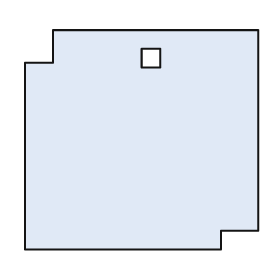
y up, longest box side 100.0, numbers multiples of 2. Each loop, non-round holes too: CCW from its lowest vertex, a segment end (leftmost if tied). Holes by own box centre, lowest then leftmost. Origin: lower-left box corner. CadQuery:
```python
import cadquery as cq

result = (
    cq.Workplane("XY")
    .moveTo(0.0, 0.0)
    .lineTo(84.0, 0.0)
    .lineTo(84.0, 8.0)
    .lineTo(100.0, 8.0)
    .lineTo(100.0, 94.0)
    .lineTo(12.0, 94.0)
    .lineTo(12.0, 80.0)
    .lineTo(0.0, 80.0)
    .close()
    .moveTo(50.0, 78.0)
    .lineTo(58.0, 78.0)
    .lineTo(58.0, 86.0)
    .lineTo(50.0, 86.0)
    .close()
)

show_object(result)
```